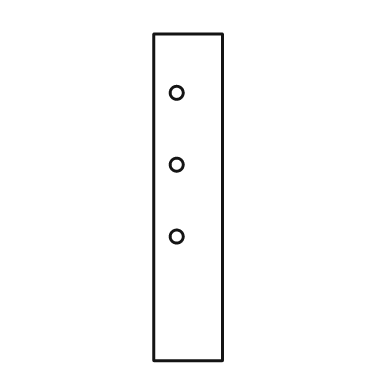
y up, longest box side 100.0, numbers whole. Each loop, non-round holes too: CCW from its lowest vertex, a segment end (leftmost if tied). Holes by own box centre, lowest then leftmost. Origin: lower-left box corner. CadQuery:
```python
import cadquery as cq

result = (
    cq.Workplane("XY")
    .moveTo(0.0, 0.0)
    .lineTo(21.0, 0.0)
    .lineTo(21.0, 100.0)
    .lineTo(0.0, 100.0)
    .close()
    .moveTo(7.0, 38.0)
    .circle(2.0)
    .moveTo(7.0, 60.0)
    .circle(2.0)
    .moveTo(7.0, 82.0)
    .circle(2.0)
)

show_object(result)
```